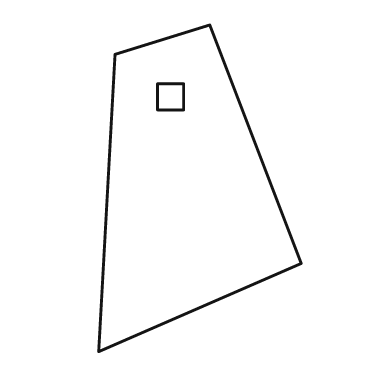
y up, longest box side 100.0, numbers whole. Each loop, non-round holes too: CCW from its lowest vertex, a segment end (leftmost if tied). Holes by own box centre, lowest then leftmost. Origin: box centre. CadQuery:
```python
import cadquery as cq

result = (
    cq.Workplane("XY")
    .moveTo(-31.0, -50.0)
    .lineTo(31.0, -23.0)
    .lineTo(3.0, 50.0)
    .lineTo(-26.0, 41.0)
    .close()
    .moveTo(-13.0, 24.0)
    .lineTo(-5.0, 24.0)
    .lineTo(-5.0, 32.0)
    .lineTo(-13.0, 32.0)
    .close()
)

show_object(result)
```